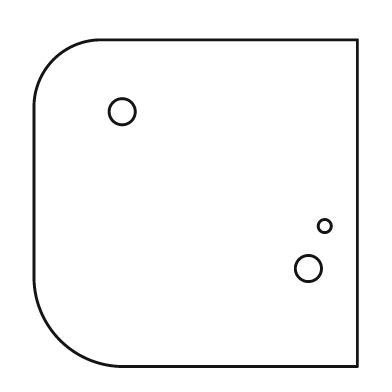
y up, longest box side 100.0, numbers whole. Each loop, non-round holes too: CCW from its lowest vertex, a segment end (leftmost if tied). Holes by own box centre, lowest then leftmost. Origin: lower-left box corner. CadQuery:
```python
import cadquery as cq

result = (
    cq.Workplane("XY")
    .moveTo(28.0, 0.0)
    .lineTo(99.0, 0.0)
    .lineTo(99.0, 100.0)
    .lineTo(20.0, 100.0)
    .threePointArc((6.0, 94.0), (0.0, 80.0))
    .lineTo(0.0, 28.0)
    .threePointArc((8.0, 8.0), (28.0, 0.0))
    .close()
    .moveTo(84.0, 30.0)
    .circle(4.0)
    .moveTo(89.0, 43.0)
    .circle(2.0)
    .moveTo(27.0, 78.0)
    .circle(4.0)
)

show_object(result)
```